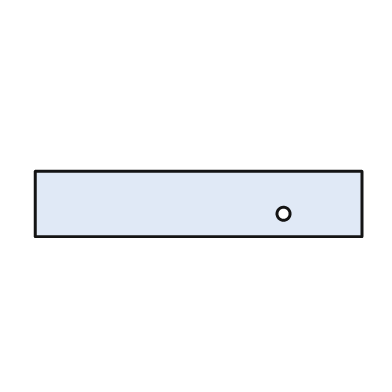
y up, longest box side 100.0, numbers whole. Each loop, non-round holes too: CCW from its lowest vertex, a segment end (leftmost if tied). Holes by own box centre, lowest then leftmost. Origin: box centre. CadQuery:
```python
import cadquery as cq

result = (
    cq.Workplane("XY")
    .moveTo(-50.0, -10.0)
    .lineTo(50.0, -10.0)
    .lineTo(50.0, 10.0)
    .lineTo(-50.0, 10.0)
    .close()
    .moveTo(26.0, -3.0)
    .circle(2.0)
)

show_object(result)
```